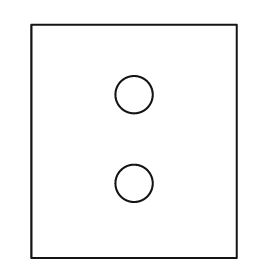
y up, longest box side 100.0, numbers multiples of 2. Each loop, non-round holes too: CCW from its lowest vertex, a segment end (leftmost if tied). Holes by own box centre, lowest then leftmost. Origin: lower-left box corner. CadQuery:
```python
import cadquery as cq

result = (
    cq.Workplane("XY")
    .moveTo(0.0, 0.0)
    .lineTo(88.0, 0.0)
    .lineTo(88.0, 100.0)
    .lineTo(0.0, 100.0)
    .close()
    .moveTo(44.0, 32.0)
    .circle(8.0)
    .moveTo(44.0, 70.0)
    .circle(8.0)
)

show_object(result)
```